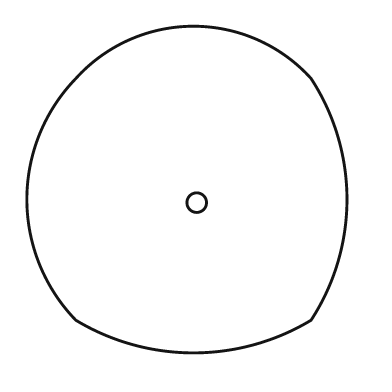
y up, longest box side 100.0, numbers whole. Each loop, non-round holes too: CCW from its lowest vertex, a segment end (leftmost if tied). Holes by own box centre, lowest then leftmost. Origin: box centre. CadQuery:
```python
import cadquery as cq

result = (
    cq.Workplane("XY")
    .moveTo(-34.0, -40.0)
    .threePointArc((2.0, -50.0), (38.0, -40.0))
    .threePointArc((49.0, -3.0), (38.0, 34.0))
    .threePointArc((2.0, 50.0), (-34.0, 34.0))
    .threePointArc((-49.0, -3.0), (-34.0, -40.0))
    .close()
    .moveTo(3.0, -4.0)
    .circle(3.0)
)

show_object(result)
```